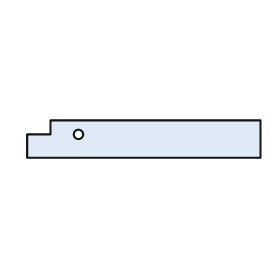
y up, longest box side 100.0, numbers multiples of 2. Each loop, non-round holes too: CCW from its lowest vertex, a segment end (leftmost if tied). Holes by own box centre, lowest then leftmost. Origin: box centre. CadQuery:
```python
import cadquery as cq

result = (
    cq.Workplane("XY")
    .moveTo(-50.0, -8.0)
    .lineTo(50.0, -8.0)
    .lineTo(50.0, 8.0)
    .lineTo(-40.0, 8.0)
    .lineTo(-40.0, 2.0)
    .lineTo(-50.0, 2.0)
    .close()
    .moveTo(-28.0, 2.0)
    .circle(2.0)
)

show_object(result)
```